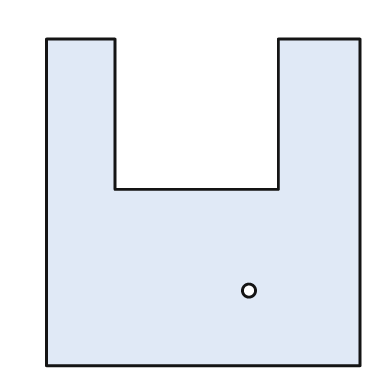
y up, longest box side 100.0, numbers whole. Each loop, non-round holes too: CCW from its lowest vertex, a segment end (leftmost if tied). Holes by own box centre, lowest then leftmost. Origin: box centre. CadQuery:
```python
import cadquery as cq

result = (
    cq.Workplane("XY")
    .moveTo(-48.0, -50.0)
    .lineTo(48.0, -50.0)
    .lineTo(48.0, 50.0)
    .lineTo(23.0, 50.0)
    .lineTo(23.0, 4.0)
    .lineTo(-27.0, 4.0)
    .lineTo(-27.0, 50.0)
    .lineTo(-48.0, 50.0)
    .close()
    .moveTo(14.0, -27.0)
    .circle(2.0)
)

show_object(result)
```